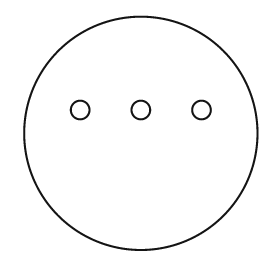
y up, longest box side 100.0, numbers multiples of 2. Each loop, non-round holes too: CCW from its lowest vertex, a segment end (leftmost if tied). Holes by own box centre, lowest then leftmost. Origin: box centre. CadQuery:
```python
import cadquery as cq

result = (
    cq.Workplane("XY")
    .moveTo(0.0, 0.0)
    .circle(50.0)
    .moveTo(-26.0, 10.0)
    .circle(4.0)
    .moveTo(0.0, 10.0)
    .circle(4.0)
    .moveTo(26.0, 10.0)
    .circle(4.0)
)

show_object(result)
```